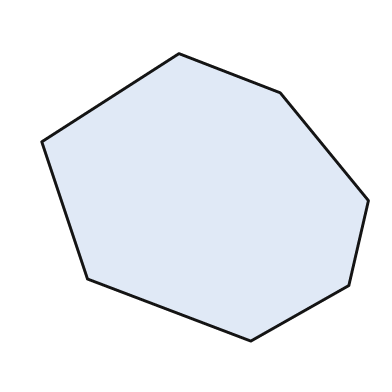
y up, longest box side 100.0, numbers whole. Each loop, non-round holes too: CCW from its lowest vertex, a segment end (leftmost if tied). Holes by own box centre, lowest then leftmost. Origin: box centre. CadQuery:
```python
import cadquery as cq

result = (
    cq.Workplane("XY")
    .moveTo(14.0, -44.0)
    .lineTo(44.0, -27.0)
    .lineTo(50.0, -1.0)
    .lineTo(23.0, 32.0)
    .lineTo(-8.0, 44.0)
    .lineTo(-50.0, 17.0)
    .lineTo(-36.0, -25.0)
    .close()
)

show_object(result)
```